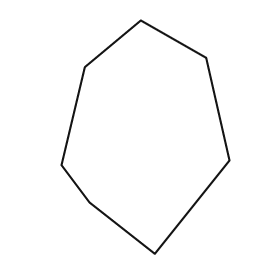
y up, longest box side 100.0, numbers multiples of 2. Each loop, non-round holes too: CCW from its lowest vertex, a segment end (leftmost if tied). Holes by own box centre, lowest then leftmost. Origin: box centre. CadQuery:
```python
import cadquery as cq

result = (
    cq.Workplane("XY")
    .moveTo(4.0, -50.0)
    .lineTo(36.0, -10.0)
    .lineTo(26.0, 34.0)
    .lineTo(-2.0, 50.0)
    .lineTo(-26.0, 30.0)
    .lineTo(-36.0, -12.0)
    .lineTo(-24.0, -28.0)
    .close()
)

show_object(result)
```